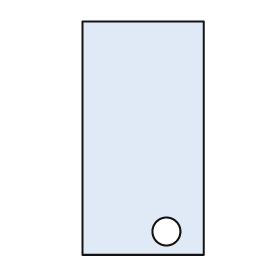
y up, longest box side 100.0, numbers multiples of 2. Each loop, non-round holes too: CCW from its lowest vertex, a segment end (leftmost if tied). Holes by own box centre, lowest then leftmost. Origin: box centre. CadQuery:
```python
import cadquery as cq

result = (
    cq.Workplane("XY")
    .moveTo(-26.0, -50.0)
    .lineTo(26.0, -50.0)
    .lineTo(26.0, 50.0)
    .lineTo(-26.0, 50.0)
    .close()
    .moveTo(10.0, -40.0)
    .circle(6.0)
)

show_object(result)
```